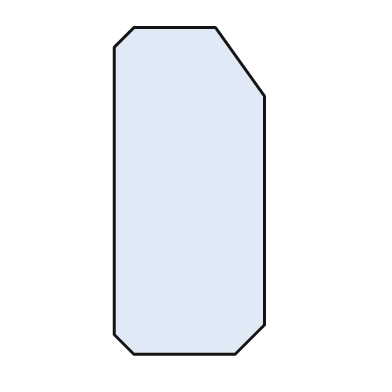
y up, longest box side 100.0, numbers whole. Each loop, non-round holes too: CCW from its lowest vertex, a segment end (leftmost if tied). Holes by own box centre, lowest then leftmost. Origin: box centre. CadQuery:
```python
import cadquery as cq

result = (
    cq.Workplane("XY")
    .moveTo(-17.0, -50.0)
    .lineTo(14.0, -50.0)
    .lineTo(23.0, -41.0)
    .lineTo(23.0, 29.0)
    .lineTo(8.0, 50.0)
    .lineTo(-17.0, 50.0)
    .lineTo(-23.0, 44.0)
    .lineTo(-23.0, -44.0)
    .close()
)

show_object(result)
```